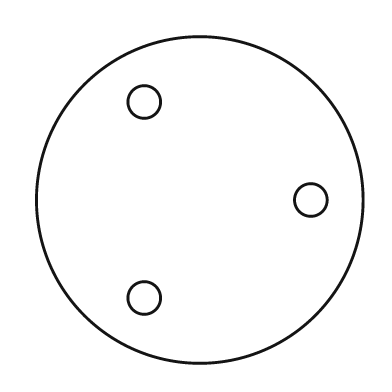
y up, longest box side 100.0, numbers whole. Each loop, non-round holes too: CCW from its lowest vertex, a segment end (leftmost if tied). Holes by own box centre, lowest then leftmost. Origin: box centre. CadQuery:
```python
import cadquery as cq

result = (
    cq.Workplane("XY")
    .moveTo(0.0, 0.0)
    .circle(50.0)
    .moveTo(-17.0, -30.0)
    .circle(5.0)
    .moveTo(34.0, 0.0)
    .circle(5.0)
    .moveTo(-17.0, 30.0)
    .circle(5.0)
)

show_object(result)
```